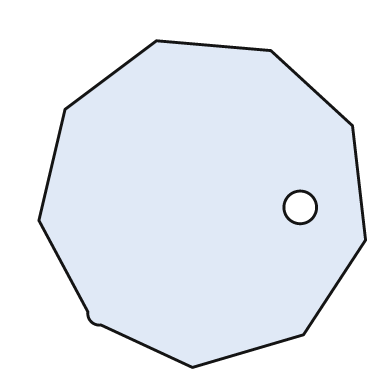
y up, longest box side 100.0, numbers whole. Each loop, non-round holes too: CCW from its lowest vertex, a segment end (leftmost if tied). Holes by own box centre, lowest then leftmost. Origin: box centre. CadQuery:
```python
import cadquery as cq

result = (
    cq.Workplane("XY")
    .moveTo(-3.0, -50.0)
    .lineTo(31.0, -40.0)
    .lineTo(50.0, -11.0)
    .lineTo(46.0, 24.0)
    .lineTo(21.0, 47.0)
    .lineTo(-14.0, 50.0)
    .lineTo(-42.0, 29.0)
    .lineTo(-50.0, -5.0)
    .lineTo(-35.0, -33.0)
    .threePointArc((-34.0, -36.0), (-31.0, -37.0))
    .close()
    .moveTo(30.0, -1.0)
    .circle(5.0)
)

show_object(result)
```